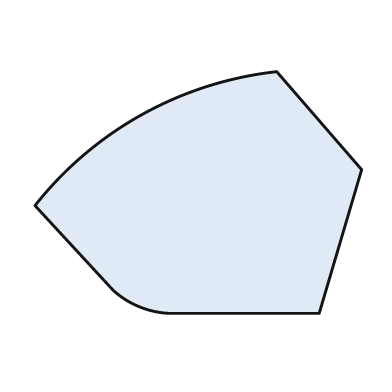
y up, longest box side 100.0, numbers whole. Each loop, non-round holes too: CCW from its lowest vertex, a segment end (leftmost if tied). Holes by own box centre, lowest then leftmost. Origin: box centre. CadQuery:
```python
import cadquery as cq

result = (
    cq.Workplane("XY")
    .moveTo(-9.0, -37.0)
    .lineTo(37.0, -37.0)
    .lineTo(50.0, 7.0)
    .lineTo(24.0, 37.0)
    .threePointArc((-17.0, 24.0), (-50.0, -4.0))
    .lineTo(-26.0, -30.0)
    .threePointArc((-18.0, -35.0), (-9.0, -37.0))
    .close()
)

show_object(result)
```